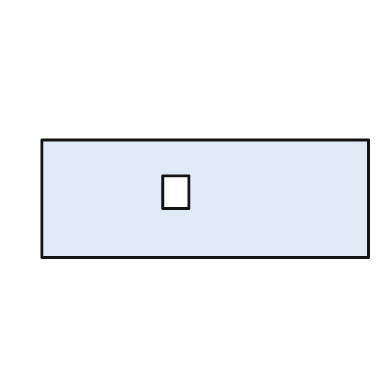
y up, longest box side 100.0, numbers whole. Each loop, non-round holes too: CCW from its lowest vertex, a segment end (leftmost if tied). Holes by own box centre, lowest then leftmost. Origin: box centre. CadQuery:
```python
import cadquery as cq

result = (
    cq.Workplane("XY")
    .moveTo(-50.0, -18.0)
    .lineTo(50.0, -18.0)
    .lineTo(50.0, 18.0)
    .lineTo(-50.0, 18.0)
    .close()
    .moveTo(-13.0, -3.0)
    .lineTo(-5.0, -3.0)
    .lineTo(-5.0, 7.0)
    .lineTo(-13.0, 7.0)
    .close()
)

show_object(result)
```